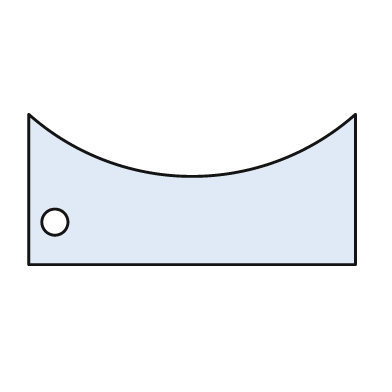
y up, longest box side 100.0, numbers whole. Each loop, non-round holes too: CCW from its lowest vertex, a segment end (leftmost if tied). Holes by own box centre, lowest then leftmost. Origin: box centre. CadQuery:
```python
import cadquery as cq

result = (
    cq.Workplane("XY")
    .moveTo(-50.0, -23.0)
    .lineTo(50.0, -23.0)
    .lineTo(50.0, 23.0)
    .threePointArc((0.0, 4.0), (-50.0, 23.0))
    .close()
    .moveTo(-42.0, -10.0)
    .circle(4.0)
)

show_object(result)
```